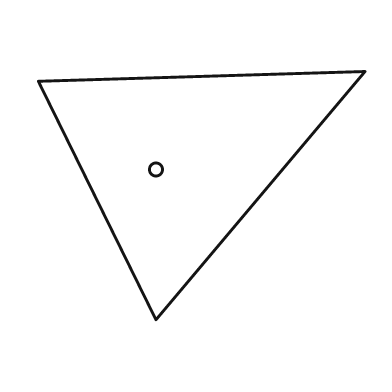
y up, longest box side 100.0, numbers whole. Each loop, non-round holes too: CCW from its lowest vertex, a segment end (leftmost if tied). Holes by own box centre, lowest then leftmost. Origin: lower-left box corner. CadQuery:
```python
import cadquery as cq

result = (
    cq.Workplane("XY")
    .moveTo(36.0, 0.0)
    .lineTo(100.0, 76.0)
    .lineTo(0.0, 73.0)
    .close()
    .moveTo(36.0, 46.0)
    .circle(2.0)
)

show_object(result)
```